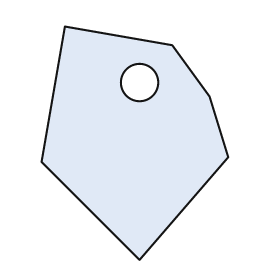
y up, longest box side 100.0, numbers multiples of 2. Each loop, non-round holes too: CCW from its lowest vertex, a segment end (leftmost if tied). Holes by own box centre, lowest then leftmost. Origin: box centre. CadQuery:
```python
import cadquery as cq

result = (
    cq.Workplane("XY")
    .moveTo(2.0, -50.0)
    .lineTo(40.0, -6.0)
    .lineTo(32.0, 20.0)
    .lineTo(16.0, 42.0)
    .lineTo(-30.0, 50.0)
    .lineTo(-40.0, -8.0)
    .close()
    .moveTo(2.0, 26.0)
    .circle(8.0)
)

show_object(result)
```